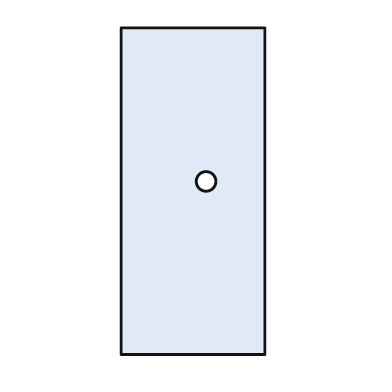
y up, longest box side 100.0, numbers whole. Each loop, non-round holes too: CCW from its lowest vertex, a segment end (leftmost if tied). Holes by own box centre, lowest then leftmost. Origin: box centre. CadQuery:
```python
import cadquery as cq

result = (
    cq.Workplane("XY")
    .moveTo(-22.0, -50.0)
    .lineTo(22.0, -50.0)
    .lineTo(22.0, 50.0)
    .lineTo(-22.0, 50.0)
    .close()
    .moveTo(4.0, 3.0)
    .circle(3.0)
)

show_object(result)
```